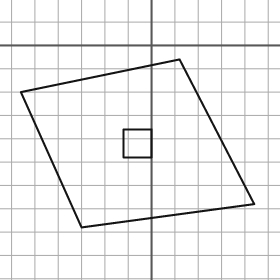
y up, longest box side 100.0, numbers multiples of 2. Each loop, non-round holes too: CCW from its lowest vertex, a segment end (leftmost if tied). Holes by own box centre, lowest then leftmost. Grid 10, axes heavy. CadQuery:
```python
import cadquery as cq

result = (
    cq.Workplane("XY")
    .moveTo(-30.0, -78.0)
    .lineTo(44.0, -68.0)
    .lineTo(12.0, -6.0)
    .lineTo(-56.0, -20.0)
    .close()
    .moveTo(-12.0, -48.0)
    .lineTo(0.0, -48.0)
    .lineTo(0.0, -36.0)
    .lineTo(-12.0, -36.0)
    .close()
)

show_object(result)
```